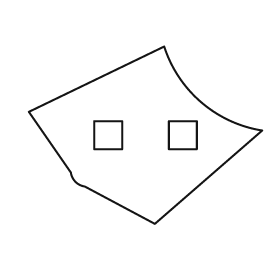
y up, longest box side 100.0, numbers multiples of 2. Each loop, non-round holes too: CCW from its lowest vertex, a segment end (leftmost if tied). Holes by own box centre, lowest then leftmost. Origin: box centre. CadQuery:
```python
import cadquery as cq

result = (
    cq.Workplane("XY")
    .moveTo(4.0, -38.0)
    .lineTo(50.0, 2.0)
    .threePointArc((24.0, 14.0), (8.0, 38.0))
    .lineTo(-50.0, 10.0)
    .lineTo(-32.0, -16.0)
    .threePointArc((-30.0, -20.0), (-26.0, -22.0))
    .close()
    .moveTo(-22.0, -6.0)
    .lineTo(-10.0, -6.0)
    .lineTo(-10.0, 6.0)
    .lineTo(-22.0, 6.0)
    .close()
    .moveTo(10.0, -6.0)
    .lineTo(22.0, -6.0)
    .lineTo(22.0, 6.0)
    .lineTo(10.0, 6.0)
    .close()
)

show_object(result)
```